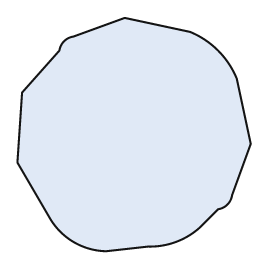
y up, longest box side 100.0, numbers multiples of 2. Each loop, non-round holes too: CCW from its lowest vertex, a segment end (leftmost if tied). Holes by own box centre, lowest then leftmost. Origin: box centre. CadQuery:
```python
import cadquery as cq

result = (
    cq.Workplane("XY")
    .moveTo(-12.0, -50.0)
    .lineTo(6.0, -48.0)
    .threePointArc((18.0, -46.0), (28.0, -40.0))
    .lineTo(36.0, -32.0)
    .threePointArc((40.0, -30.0), (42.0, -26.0))
    .lineTo(50.0, -4.0)
    .lineTo(44.0, 24.0)
    .threePointArc((36.0, 36.0), (24.0, 44.0))
    .lineTo(-4.0, 50.0)
    .lineTo(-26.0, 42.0)
    .threePointArc((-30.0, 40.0), (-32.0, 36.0))
    .lineTo(-48.0, 18.0)
    .lineTo(-50.0, -12.0)
    .lineTo(-36.0, -36.0)
    .threePointArc((-26.0, -46.0), (-12.0, -50.0))
    .close()
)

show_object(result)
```